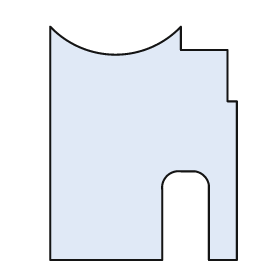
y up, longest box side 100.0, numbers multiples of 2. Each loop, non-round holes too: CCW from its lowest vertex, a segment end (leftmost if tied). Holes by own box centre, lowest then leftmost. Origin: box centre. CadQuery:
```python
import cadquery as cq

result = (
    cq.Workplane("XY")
    .moveTo(-40.0, -50.0)
    .lineTo(8.0, -50.0)
    .lineTo(8.0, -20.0)
    .threePointArc((10.0, -14.0), (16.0, -12.0))
    .lineTo(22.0, -12.0)
    .threePointArc((26.0, -14.0), (28.0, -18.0))
    .lineTo(28.0, -50.0)
    .lineTo(40.0, -50.0)
    .lineTo(40.0, 18.0)
    .lineTo(36.0, 18.0)
    .lineTo(36.0, 40.0)
    .lineTo(16.0, 40.0)
    .lineTo(16.0, 50.0)
    .threePointArc((-12.0, 38.0), (-40.0, 50.0))
    .close()
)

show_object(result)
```